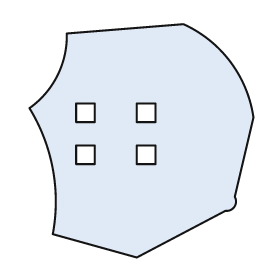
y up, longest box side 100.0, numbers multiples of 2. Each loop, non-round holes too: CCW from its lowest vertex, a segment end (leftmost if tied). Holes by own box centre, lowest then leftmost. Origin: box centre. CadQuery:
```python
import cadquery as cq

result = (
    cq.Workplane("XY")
    .moveTo(-2.0, -50.0)
    .lineTo(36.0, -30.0)
    .threePointArc((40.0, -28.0), (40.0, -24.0))
    .lineTo(48.0, 10.0)
    .threePointArc((38.0, 34.0), (18.0, 50.0))
    .lineTo(-32.0, 46.0)
    .threePointArc((-36.0, 28.0), (-48.0, 14.0))
    .threePointArc((-38.0, -12.0), (-38.0, -40.0))
    .close()
    .moveTo(-28.0, -10.0)
    .lineTo(-20.0, -10.0)
    .lineTo(-20.0, -2.0)
    .lineTo(-28.0, -2.0)
    .close()
    .moveTo(-2.0, -10.0)
    .lineTo(6.0, -10.0)
    .lineTo(6.0, -2.0)
    .lineTo(-2.0, -2.0)
    .close()
    .moveTo(-28.0, 8.0)
    .lineTo(-20.0, 8.0)
    .lineTo(-20.0, 16.0)
    .lineTo(-28.0, 16.0)
    .close()
    .moveTo(-2.0, 8.0)
    .lineTo(6.0, 8.0)
    .lineTo(6.0, 16.0)
    .lineTo(-2.0, 16.0)
    .close()
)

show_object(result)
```